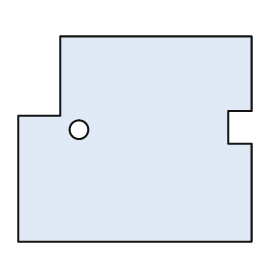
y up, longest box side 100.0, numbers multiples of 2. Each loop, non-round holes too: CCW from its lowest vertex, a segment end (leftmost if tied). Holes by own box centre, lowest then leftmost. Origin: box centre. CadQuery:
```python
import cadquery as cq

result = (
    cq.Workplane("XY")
    .moveTo(-50.0, -44.0)
    .lineTo(50.0, -44.0)
    .lineTo(50.0, -2.0)
    .lineTo(40.0, -2.0)
    .lineTo(40.0, 12.0)
    .lineTo(50.0, 12.0)
    .lineTo(50.0, 44.0)
    .lineTo(-32.0, 44.0)
    .lineTo(-32.0, 10.0)
    .lineTo(-50.0, 10.0)
    .close()
    .moveTo(-24.0, 4.0)
    .circle(4.0)
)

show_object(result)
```